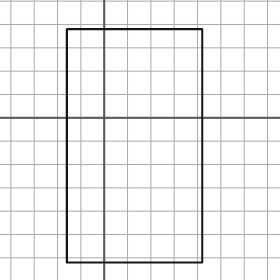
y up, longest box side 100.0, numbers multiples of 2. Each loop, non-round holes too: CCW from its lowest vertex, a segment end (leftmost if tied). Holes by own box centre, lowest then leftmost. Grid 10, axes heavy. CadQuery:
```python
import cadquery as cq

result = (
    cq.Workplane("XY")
    .moveTo(-16.0, -62.0)
    .lineTo(42.0, -62.0)
    .lineTo(42.0, 38.0)
    .lineTo(-16.0, 38.0)
    .close()
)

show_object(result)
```